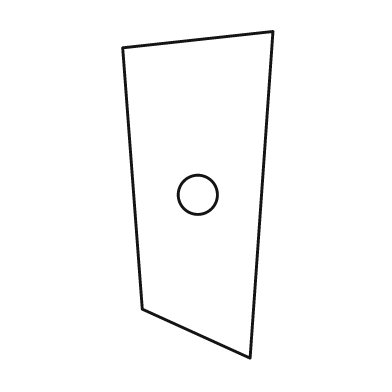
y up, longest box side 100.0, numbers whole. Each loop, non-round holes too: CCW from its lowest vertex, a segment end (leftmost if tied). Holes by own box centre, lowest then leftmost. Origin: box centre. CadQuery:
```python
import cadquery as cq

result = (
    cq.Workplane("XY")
    .moveTo(16.0, -50.0)
    .lineTo(23.0, 50.0)
    .lineTo(-23.0, 45.0)
    .lineTo(-17.0, -35.0)
    .close()
    .moveTo(0.0, 0.0)
    .circle(6.0)
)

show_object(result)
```